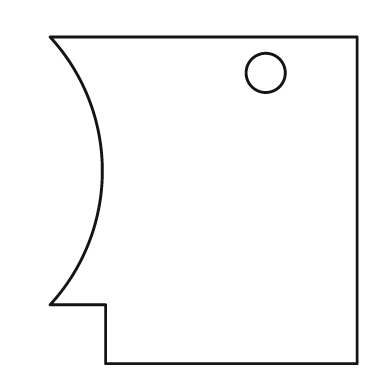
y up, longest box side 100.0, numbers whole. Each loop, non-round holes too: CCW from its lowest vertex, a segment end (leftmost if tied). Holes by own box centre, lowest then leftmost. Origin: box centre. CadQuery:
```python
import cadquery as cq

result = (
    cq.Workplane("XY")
    .moveTo(-30.0, -50.0)
    .lineTo(47.0, -50.0)
    .lineTo(47.0, 50.0)
    .lineTo(-47.0, 50.0)
    .threePointArc((-31.0, 9.0), (-47.0, -32.0))
    .lineTo(-30.0, -32.0)
    .close()
    .moveTo(19.0, 39.0)
    .circle(6.0)
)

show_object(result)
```